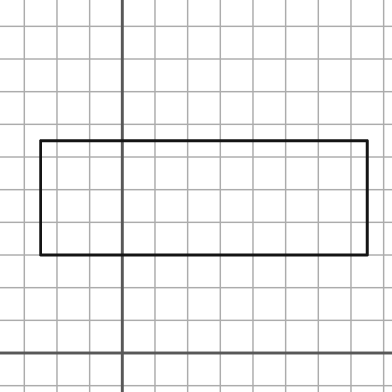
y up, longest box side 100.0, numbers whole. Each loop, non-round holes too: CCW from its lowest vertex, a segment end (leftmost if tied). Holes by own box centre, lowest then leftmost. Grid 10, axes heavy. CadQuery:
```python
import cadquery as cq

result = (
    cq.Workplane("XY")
    .moveTo(-25.0, 30.0)
    .lineTo(75.0, 30.0)
    .lineTo(75.0, 65.0)
    .lineTo(-25.0, 65.0)
    .close()
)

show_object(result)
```